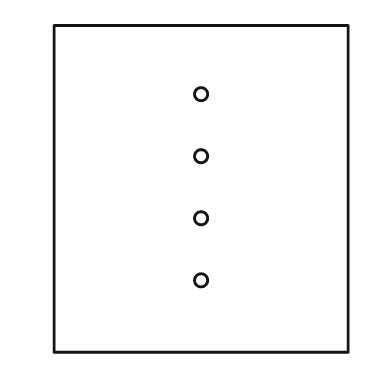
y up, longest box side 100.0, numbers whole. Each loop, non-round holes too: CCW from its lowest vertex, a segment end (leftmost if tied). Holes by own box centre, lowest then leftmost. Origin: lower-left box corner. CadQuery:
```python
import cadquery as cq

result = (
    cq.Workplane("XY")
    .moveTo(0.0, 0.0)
    .lineTo(90.0, 0.0)
    .lineTo(90.0, 100.0)
    .lineTo(0.0, 100.0)
    .close()
    .moveTo(45.0, 22.0)
    .circle(2.0)
    .moveTo(45.0, 41.0)
    .circle(2.0)
    .moveTo(45.0, 60.0)
    .circle(2.0)
    .moveTo(45.0, 79.0)
    .circle(2.0)
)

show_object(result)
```